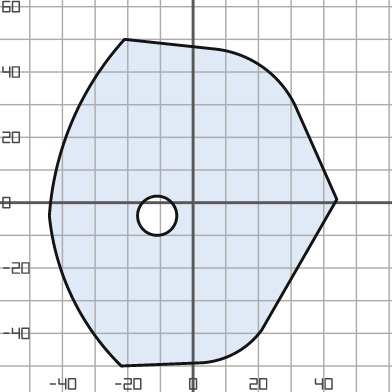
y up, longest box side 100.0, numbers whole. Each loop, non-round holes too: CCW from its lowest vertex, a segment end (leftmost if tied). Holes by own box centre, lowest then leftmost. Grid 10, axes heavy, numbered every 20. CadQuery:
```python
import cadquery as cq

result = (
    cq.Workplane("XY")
    .moveTo(-22.0, -50.0)
    .lineTo(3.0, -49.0)
    .threePointArc((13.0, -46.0), (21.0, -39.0))
    .lineTo(44.0, 1.0)
    .lineTo(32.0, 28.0)
    .threePointArc((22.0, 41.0), (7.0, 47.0))
    .lineTo(-21.0, 50.0)
    .threePointArc((-37.0, 25.0), (-44.0, -4.0))
    .threePointArc((-37.0, -29.0), (-22.0, -50.0))
    .close()
    .moveTo(-11.0, -4.0)
    .circle(6.0)
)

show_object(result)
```